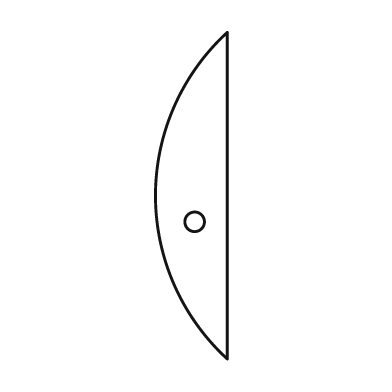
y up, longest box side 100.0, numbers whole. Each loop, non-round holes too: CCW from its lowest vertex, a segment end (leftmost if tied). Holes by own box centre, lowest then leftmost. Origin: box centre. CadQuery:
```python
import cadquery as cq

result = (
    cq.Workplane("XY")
    .moveTo(11.0, -50.0)
    .lineTo(11.0, 50.0)
    .threePointArc((-11.0, 0.0), (11.0, -50.0))
    .close()
    .moveTo(1.0, -8.0)
    .circle(3.0)
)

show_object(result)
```